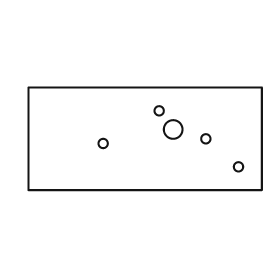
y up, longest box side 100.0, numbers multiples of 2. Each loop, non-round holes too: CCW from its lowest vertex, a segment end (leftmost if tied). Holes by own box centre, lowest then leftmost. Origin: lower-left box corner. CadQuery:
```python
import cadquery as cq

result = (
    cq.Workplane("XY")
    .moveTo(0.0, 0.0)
    .lineTo(100.0, 0.0)
    .lineTo(100.0, 44.0)
    .lineTo(0.0, 44.0)
    .close()
    .moveTo(90.0, 10.0)
    .circle(2.0)
    .moveTo(32.0, 20.0)
    .circle(2.0)
    .moveTo(76.0, 22.0)
    .circle(2.0)
    .moveTo(62.0, 26.0)
    .circle(4.0)
    .moveTo(56.0, 34.0)
    .circle(2.0)
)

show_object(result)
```